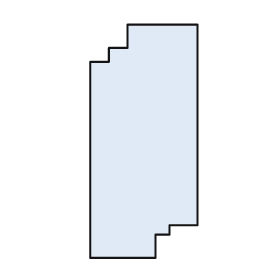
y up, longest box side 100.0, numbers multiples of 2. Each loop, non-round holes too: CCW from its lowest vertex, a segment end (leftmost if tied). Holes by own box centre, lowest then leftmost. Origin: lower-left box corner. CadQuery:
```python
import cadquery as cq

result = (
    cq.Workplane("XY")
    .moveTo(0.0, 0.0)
    .lineTo(28.0, 0.0)
    .lineTo(28.0, 10.0)
    .lineTo(34.0, 10.0)
    .lineTo(34.0, 14.0)
    .lineTo(46.0, 14.0)
    .lineTo(46.0, 100.0)
    .lineTo(16.0, 100.0)
    .lineTo(16.0, 90.0)
    .lineTo(8.0, 90.0)
    .lineTo(8.0, 84.0)
    .lineTo(0.0, 84.0)
    .close()
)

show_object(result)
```